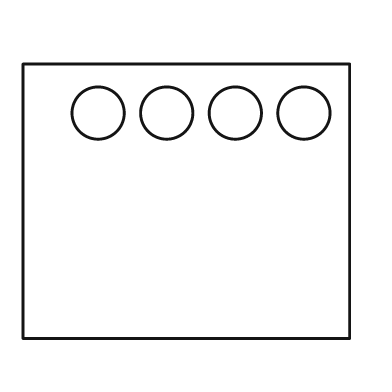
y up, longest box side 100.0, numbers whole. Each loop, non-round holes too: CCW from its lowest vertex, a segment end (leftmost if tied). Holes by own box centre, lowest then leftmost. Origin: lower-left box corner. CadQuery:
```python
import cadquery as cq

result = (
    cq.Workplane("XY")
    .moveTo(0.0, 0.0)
    .lineTo(100.0, 0.0)
    .lineTo(100.0, 84.0)
    .lineTo(0.0, 84.0)
    .close()
    .moveTo(23.0, 69.0)
    .circle(8.0)
    .moveTo(44.0, 69.0)
    .circle(8.0)
    .moveTo(65.0, 69.0)
    .circle(8.0)
    .moveTo(86.0, 69.0)
    .circle(8.0)
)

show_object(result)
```